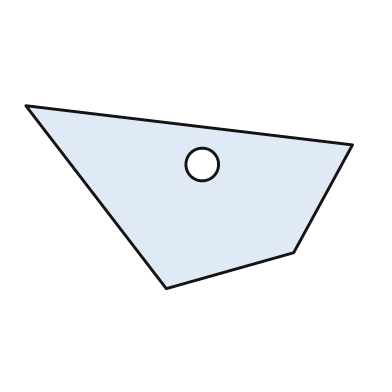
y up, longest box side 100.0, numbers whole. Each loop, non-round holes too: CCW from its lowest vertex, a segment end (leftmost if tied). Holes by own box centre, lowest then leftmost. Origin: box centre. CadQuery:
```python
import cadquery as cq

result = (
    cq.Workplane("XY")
    .moveTo(-7.0, -28.0)
    .lineTo(32.0, -17.0)
    .lineTo(50.0, 16.0)
    .lineTo(-50.0, 28.0)
    .close()
    .moveTo(4.0, 10.0)
    .circle(5.0)
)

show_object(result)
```